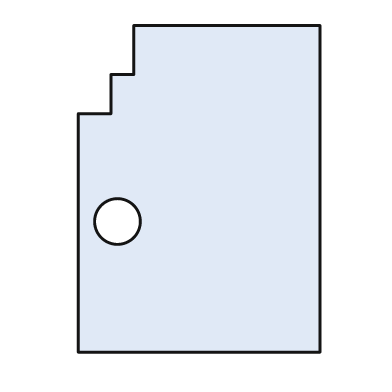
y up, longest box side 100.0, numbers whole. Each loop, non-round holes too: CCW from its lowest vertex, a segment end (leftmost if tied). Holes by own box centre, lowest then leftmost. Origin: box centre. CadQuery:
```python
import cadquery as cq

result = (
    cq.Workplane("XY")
    .moveTo(-37.0, -50.0)
    .lineTo(37.0, -50.0)
    .lineTo(37.0, 50.0)
    .lineTo(-20.0, 50.0)
    .lineTo(-20.0, 35.0)
    .lineTo(-27.0, 35.0)
    .lineTo(-27.0, 23.0)
    .lineTo(-37.0, 23.0)
    .close()
    .moveTo(-25.0, -10.0)
    .circle(7.0)
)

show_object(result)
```